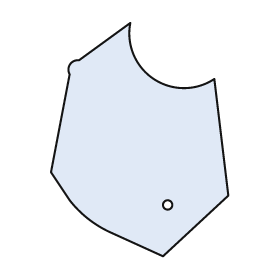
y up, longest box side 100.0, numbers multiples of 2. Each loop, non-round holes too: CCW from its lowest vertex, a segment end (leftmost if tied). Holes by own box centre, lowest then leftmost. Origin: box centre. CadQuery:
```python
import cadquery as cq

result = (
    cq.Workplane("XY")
    .moveTo(10.0, -50.0)
    .lineTo(38.0, -24.0)
    .lineTo(32.0, 26.0)
    .threePointArc((6.0, 26.0), (-4.0, 50.0))
    .lineTo(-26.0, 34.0)
    .threePointArc((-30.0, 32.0), (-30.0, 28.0))
    .lineTo(-38.0, -14.0)
    .lineTo(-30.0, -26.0)
    .threePointArc((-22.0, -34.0), (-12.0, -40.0))
    .close()
    .moveTo(12.0, -28.0)
    .circle(2.0)
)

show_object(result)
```